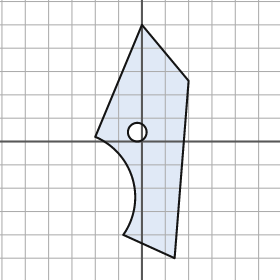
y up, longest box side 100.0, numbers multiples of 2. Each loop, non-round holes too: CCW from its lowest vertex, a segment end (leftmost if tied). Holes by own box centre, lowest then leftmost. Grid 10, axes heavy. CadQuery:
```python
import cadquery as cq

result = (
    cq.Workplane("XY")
    .moveTo(14.0, -50.0)
    .lineTo(20.0, 26.0)
    .lineTo(0.0, 50.0)
    .lineTo(-20.0, 2.0)
    .threePointArc((-4.0, -16.0), (-8.0, -40.0))
    .close()
    .moveTo(-2.0, 4.0)
    .circle(4.0)
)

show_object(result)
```